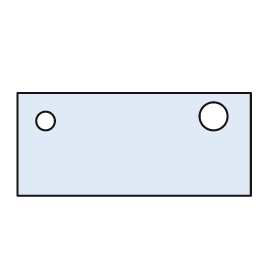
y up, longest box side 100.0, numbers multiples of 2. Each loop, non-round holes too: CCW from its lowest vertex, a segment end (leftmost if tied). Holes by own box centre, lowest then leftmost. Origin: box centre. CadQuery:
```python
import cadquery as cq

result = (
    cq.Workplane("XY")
    .moveTo(-50.0, -22.0)
    .lineTo(50.0, -22.0)
    .lineTo(50.0, 22.0)
    .lineTo(-50.0, 22.0)
    .close()
    .moveTo(-38.0, 10.0)
    .circle(4.0)
    .moveTo(34.0, 12.0)
    .circle(6.0)
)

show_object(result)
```